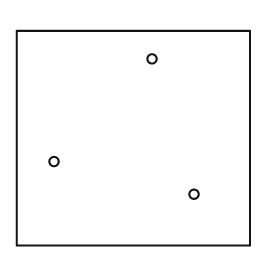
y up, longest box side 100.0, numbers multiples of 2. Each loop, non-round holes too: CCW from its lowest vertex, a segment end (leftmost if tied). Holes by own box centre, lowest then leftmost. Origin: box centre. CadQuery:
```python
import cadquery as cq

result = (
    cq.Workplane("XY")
    .moveTo(-50.0, -46.0)
    .lineTo(50.0, -46.0)
    .lineTo(50.0, 46.0)
    .lineTo(-50.0, 46.0)
    .close()
    .moveTo(26.0, -24.0)
    .circle(2.0)
    .moveTo(-34.0, -10.0)
    .circle(2.0)
    .moveTo(8.0, 34.0)
    .circle(2.0)
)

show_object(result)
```